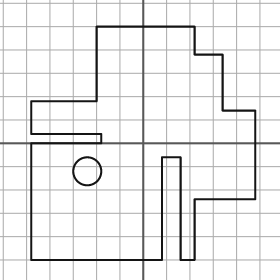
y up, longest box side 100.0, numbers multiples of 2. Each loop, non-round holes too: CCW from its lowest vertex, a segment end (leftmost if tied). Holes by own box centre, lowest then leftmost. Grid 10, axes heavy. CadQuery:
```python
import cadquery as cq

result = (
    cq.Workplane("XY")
    .moveTo(-48.0, -50.0)
    .lineTo(8.0, -50.0)
    .lineTo(8.0, -6.0)
    .lineTo(16.0, -6.0)
    .lineTo(16.0, -50.0)
    .lineTo(22.0, -50.0)
    .lineTo(22.0, -24.0)
    .lineTo(48.0, -24.0)
    .lineTo(48.0, 14.0)
    .lineTo(34.0, 14.0)
    .lineTo(34.0, 38.0)
    .lineTo(22.0, 38.0)
    .lineTo(22.0, 50.0)
    .lineTo(-20.0, 50.0)
    .lineTo(-20.0, 18.0)
    .lineTo(-48.0, 18.0)
    .lineTo(-48.0, 4.0)
    .lineTo(-18.0, 4.0)
    .lineTo(-18.0, 0.0)
    .lineTo(-48.0, 0.0)
    .close()
    .moveTo(-24.0, -12.0)
    .circle(6.0)
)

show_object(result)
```